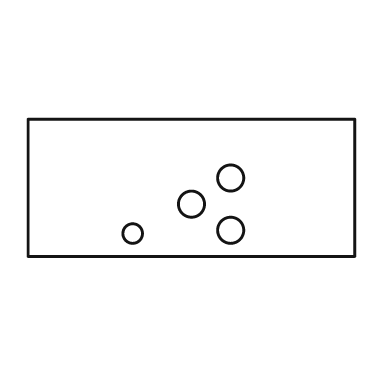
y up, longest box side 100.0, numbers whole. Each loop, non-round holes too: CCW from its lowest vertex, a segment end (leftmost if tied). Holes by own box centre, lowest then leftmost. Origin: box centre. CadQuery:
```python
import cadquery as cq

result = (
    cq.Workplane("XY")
    .moveTo(-50.0, -21.0)
    .lineTo(50.0, -21.0)
    .lineTo(50.0, 21.0)
    .lineTo(-50.0, 21.0)
    .close()
    .moveTo(-18.0, -14.0)
    .circle(3.0)
    .moveTo(12.0, -13.0)
    .circle(4.0)
    .moveTo(0.0, -5.0)
    .circle(4.0)
    .moveTo(12.0, 3.0)
    .circle(4.0)
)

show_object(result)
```